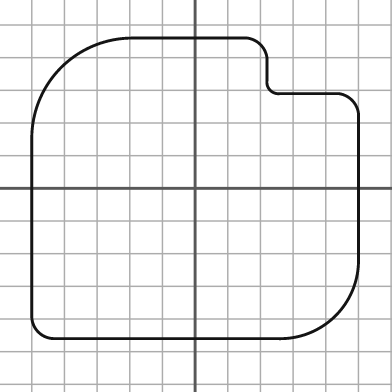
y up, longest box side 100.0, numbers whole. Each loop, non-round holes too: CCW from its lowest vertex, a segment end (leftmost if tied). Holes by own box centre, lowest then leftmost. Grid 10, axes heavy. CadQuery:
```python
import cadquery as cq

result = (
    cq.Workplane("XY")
    .moveTo(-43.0, -46.0)
    .lineTo(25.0, -46.0)
    .threePointArc((43.0, -39.0), (50.0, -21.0))
    .lineTo(50.0, 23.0)
    .threePointArc((48.0, 27.0), (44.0, 29.0))
    .lineTo(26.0, 29.0)
    .threePointArc((23.0, 30.0), (22.0, 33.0))
    .lineTo(22.0, 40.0)
    .threePointArc((20.0, 44.0), (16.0, 46.0))
    .lineTo(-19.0, 46.0)
    .threePointArc((-41.0, 37.0), (-50.0, 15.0))
    .lineTo(-50.0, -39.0)
    .threePointArc((-48.0, -44.0), (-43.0, -46.0))
    .close()
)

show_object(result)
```